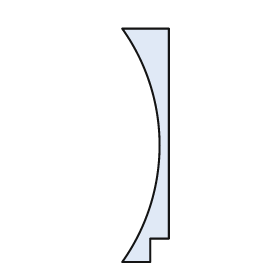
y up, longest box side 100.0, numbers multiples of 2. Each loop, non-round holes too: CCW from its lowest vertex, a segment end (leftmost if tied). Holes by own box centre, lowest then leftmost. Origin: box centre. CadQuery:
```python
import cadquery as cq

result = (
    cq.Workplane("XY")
    .moveTo(-10.0, -50.0)
    .lineTo(2.0, -50.0)
    .lineTo(2.0, -40.0)
    .lineTo(10.0, -40.0)
    .lineTo(10.0, 50.0)
    .lineTo(-10.0, 50.0)
    .threePointArc((6.0, 0.0), (-10.0, -50.0))
    .close()
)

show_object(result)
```